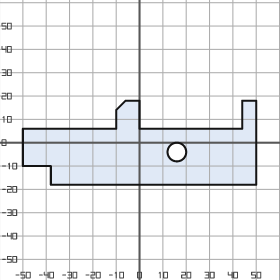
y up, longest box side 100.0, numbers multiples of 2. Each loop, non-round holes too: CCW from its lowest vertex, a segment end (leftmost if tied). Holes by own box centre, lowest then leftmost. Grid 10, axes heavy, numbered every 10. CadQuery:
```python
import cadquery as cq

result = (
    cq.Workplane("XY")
    .moveTo(-38.0, -18.0)
    .lineTo(50.0, -18.0)
    .lineTo(50.0, 18.0)
    .lineTo(44.0, 18.0)
    .lineTo(44.0, 6.0)
    .lineTo(0.0, 6.0)
    .lineTo(0.0, 18.0)
    .lineTo(-6.0, 18.0)
    .lineTo(-10.0, 14.0)
    .lineTo(-10.0, 6.0)
    .lineTo(-50.0, 6.0)
    .lineTo(-50.0, -10.0)
    .lineTo(-38.0, -10.0)
    .close()
    .moveTo(16.0, -4.0)
    .circle(4.0)
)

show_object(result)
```